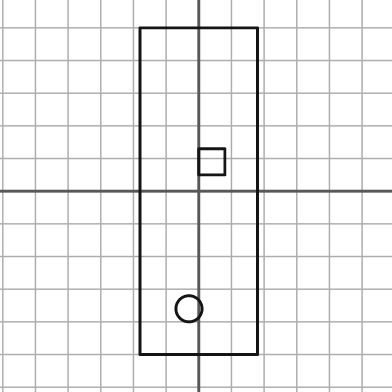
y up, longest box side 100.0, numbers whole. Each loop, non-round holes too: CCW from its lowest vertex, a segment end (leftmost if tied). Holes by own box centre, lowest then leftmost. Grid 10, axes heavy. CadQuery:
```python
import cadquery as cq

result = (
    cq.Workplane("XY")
    .moveTo(-18.0, -50.0)
    .lineTo(18.0, -50.0)
    .lineTo(18.0, 50.0)
    .lineTo(-18.0, 50.0)
    .close()
    .moveTo(-3.0, -36.0)
    .circle(4.0)
    .moveTo(0.0, 5.0)
    .lineTo(8.0, 5.0)
    .lineTo(8.0, 13.0)
    .lineTo(0.0, 13.0)
    .close()
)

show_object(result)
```